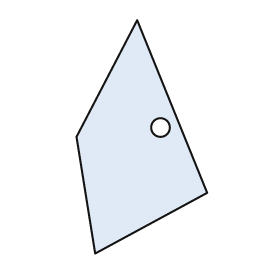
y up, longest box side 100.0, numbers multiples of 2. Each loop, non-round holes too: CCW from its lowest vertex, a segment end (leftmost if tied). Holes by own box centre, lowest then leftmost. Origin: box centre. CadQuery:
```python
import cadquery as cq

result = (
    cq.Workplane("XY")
    .moveTo(-20.0, -50.0)
    .lineTo(28.0, -24.0)
    .lineTo(-2.0, 50.0)
    .lineTo(-28.0, 0.0)
    .close()
    .moveTo(8.0, 4.0)
    .circle(4.0)
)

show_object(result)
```